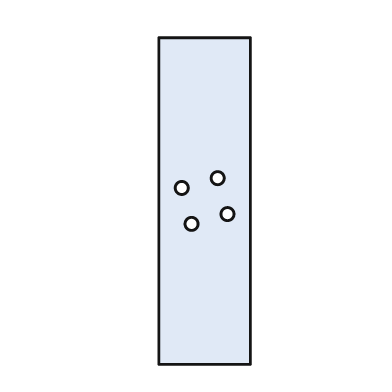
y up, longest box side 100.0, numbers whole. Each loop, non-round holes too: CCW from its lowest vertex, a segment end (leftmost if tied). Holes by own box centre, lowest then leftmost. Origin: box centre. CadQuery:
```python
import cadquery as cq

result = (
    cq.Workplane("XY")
    .moveTo(-14.0, -50.0)
    .lineTo(14.0, -50.0)
    .lineTo(14.0, 50.0)
    .lineTo(-14.0, 50.0)
    .close()
    .moveTo(-4.0, -7.0)
    .circle(2.0)
    .moveTo(7.0, -4.0)
    .circle(2.0)
    .moveTo(-7.0, 4.0)
    .circle(2.0)
    .moveTo(4.0, 7.0)
    .circle(2.0)
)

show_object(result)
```